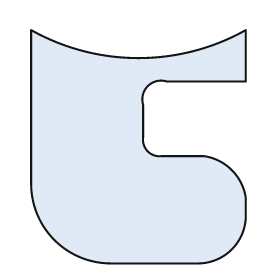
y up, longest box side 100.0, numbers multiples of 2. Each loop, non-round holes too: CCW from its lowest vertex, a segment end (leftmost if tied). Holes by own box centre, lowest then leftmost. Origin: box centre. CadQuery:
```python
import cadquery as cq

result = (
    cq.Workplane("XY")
    .moveTo(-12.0, -50.0)
    .lineTo(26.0, -50.0)
    .threePointArc((40.0, -44.0), (46.0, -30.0))
    .lineTo(46.0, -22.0)
    .threePointArc((40.0, -10.0), (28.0, -4.0))
    .lineTo(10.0, -4.0)
    .threePointArc((4.0, -2.0), (2.0, 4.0))
    .lineTo(2.0, 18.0)
    .threePointArc((4.0, 26.0), (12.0, 28.0))
    .lineTo(46.0, 28.0)
    .lineTo(46.0, 50.0)
    .threePointArc((0.0, 38.0), (-46.0, 50.0))
    .lineTo(-46.0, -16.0)
    .threePointArc((-36.0, -40.0), (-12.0, -50.0))
    .close()
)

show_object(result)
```